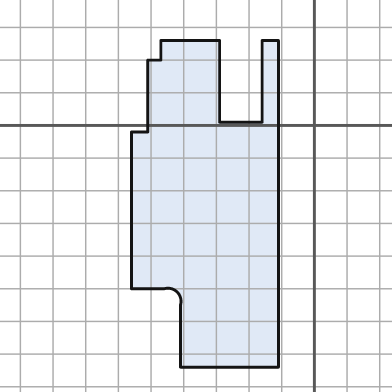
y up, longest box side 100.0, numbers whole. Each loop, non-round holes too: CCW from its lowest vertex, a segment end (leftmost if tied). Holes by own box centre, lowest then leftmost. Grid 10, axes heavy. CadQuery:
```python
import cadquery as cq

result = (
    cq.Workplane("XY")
    .moveTo(-41.0, -74.0)
    .lineTo(-11.0, -74.0)
    .lineTo(-11.0, 26.0)
    .lineTo(-16.0, 26.0)
    .lineTo(-16.0, 1.0)
    .lineTo(-29.0, 1.0)
    .lineTo(-29.0, 26.0)
    .lineTo(-47.0, 26.0)
    .lineTo(-47.0, 20.0)
    .lineTo(-51.0, 20.0)
    .lineTo(-51.0, -2.0)
    .lineTo(-56.0, -2.0)
    .lineTo(-56.0, -50.0)
    .lineTo(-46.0, -50.0)
    .threePointArc((-42.0, -51.0), (-41.0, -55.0))
    .close()
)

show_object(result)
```